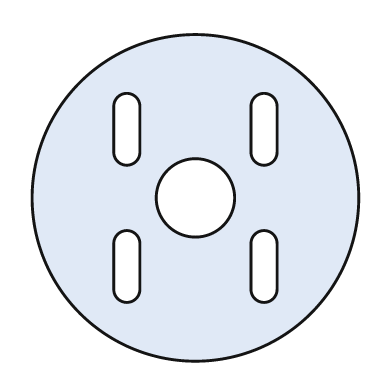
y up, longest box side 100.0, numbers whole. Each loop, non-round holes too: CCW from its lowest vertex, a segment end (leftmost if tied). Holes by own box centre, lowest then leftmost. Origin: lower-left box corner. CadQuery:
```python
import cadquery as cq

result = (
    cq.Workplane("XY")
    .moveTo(50.0, 50.0)
    .circle(50.0)
    .moveTo(25.0, 22.0)
    .threePointArc((29.0, 18.0), (33.0, 22.0))
    .lineTo(33.0, 36.0)
    .threePointArc((29.0, 40.0), (25.0, 36.0))
    .close()
    .moveTo(67.0, 22.0)
    .threePointArc((71.0, 18.0), (75.0, 22.0))
    .lineTo(75.0, 36.0)
    .threePointArc((71.0, 40.0), (67.0, 36.0))
    .close()
    .moveTo(50.0, 50.0)
    .circle(12.0)
    .moveTo(25.0, 64.0)
    .threePointArc((29.0, 60.0), (33.0, 64.0))
    .lineTo(33.0, 78.0)
    .threePointArc((29.0, 82.0), (25.0, 78.0))
    .close()
    .moveTo(67.0, 64.0)
    .threePointArc((71.0, 60.0), (75.0, 64.0))
    .lineTo(75.0, 78.0)
    .threePointArc((71.0, 82.0), (67.0, 78.0))
    .close()
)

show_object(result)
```